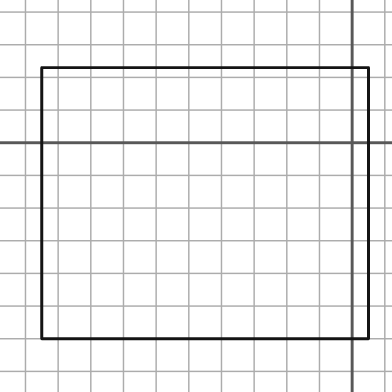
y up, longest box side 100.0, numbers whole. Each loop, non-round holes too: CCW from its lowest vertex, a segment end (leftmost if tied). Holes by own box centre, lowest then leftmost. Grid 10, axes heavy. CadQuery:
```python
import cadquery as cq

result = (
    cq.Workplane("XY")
    .moveTo(-95.0, -60.0)
    .lineTo(5.0, -60.0)
    .lineTo(5.0, 23.0)
    .lineTo(-95.0, 23.0)
    .close()
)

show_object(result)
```